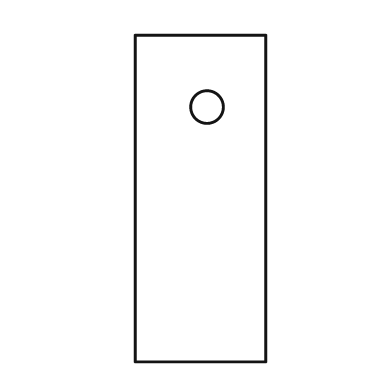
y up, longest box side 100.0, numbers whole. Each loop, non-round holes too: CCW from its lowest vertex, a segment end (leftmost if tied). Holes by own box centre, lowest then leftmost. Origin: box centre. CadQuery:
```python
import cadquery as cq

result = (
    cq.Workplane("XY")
    .moveTo(-20.0, -50.0)
    .lineTo(20.0, -50.0)
    .lineTo(20.0, 50.0)
    .lineTo(-20.0, 50.0)
    .close()
    .moveTo(2.0, 28.0)
    .circle(5.0)
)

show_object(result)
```